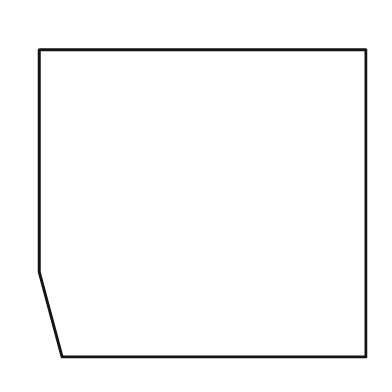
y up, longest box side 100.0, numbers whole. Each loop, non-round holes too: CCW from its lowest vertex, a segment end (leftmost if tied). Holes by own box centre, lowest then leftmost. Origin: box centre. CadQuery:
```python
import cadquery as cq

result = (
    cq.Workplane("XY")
    .moveTo(-43.0, -47.0)
    .lineTo(50.0, -47.0)
    .lineTo(50.0, 47.0)
    .lineTo(-50.0, 47.0)
    .lineTo(-50.0, -21.0)
    .close()
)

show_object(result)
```